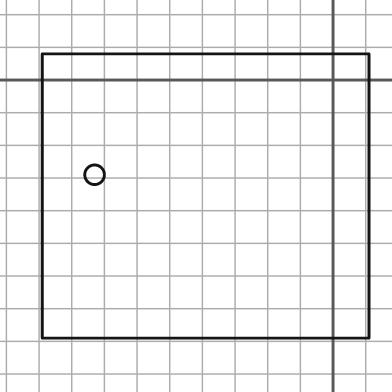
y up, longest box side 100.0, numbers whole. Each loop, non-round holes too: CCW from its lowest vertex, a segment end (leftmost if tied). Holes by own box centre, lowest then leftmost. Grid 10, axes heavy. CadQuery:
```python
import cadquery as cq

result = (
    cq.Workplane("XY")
    .moveTo(-89.0, -79.0)
    .lineTo(11.0, -79.0)
    .lineTo(11.0, 8.0)
    .lineTo(-89.0, 8.0)
    .close()
    .moveTo(-73.0, -29.0)
    .circle(3.0)
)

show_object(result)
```